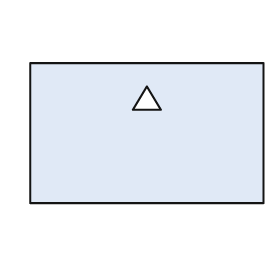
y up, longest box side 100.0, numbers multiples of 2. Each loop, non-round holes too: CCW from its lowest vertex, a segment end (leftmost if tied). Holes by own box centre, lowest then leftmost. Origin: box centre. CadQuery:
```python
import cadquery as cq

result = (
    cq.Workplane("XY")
    .moveTo(-50.0, -30.0)
    .lineTo(50.0, -30.0)
    .lineTo(50.0, 30.0)
    .lineTo(-50.0, 30.0)
    .close()
    .moveTo(-6.0, 10.0)
    .lineTo(6.0, 10.0)
    .lineTo(0.0, 20.0)
    .close()
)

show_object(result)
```